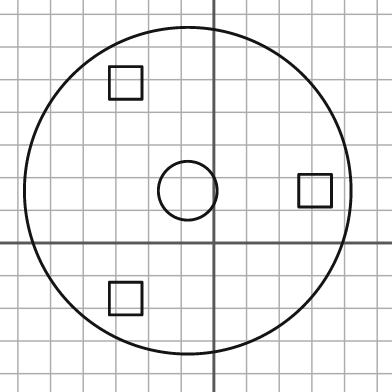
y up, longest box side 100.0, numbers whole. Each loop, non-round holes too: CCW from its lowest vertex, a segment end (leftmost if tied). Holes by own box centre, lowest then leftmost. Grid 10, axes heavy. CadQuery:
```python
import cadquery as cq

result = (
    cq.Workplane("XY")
    .moveTo(-8.0, 16.0)
    .circle(50.0)
    .moveTo(-32.0, -22.0)
    .lineTo(-22.0, -22.0)
    .lineTo(-22.0, -12.0)
    .lineTo(-32.0, -12.0)
    .close()
    .moveTo(-8.0, 16.0)
    .circle(9.0)
    .moveTo(26.0, 11.0)
    .lineTo(36.0, 11.0)
    .lineTo(36.0, 21.0)
    .lineTo(26.0, 21.0)
    .close()
    .moveTo(-32.0, 44.0)
    .lineTo(-22.0, 44.0)
    .lineTo(-22.0, 54.0)
    .lineTo(-32.0, 54.0)
    .close()
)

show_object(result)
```